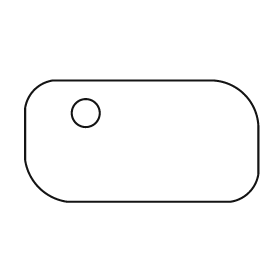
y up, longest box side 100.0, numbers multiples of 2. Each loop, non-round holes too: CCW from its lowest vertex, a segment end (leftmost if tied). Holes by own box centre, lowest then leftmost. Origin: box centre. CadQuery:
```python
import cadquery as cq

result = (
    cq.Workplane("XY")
    .moveTo(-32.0, -26.0)
    .lineTo(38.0, -26.0)
    .threePointArc((46.0, -22.0), (50.0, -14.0))
    .lineTo(50.0, 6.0)
    .threePointArc((44.0, 20.0), (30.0, 26.0))
    .lineTo(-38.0, 26.0)
    .threePointArc((-46.0, 22.0), (-50.0, 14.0))
    .lineTo(-50.0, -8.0)
    .threePointArc((-44.0, -20.0), (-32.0, -26.0))
    .close()
    .moveTo(-24.0, 12.0)
    .circle(6.0)
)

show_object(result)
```